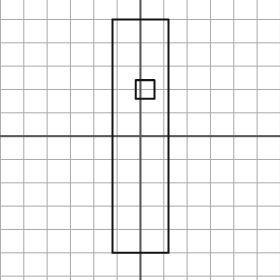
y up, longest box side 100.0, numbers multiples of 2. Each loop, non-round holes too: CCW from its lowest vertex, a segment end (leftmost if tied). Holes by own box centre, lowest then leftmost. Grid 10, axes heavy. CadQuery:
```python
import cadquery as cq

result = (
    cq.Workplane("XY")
    .moveTo(-12.0, -50.0)
    .lineTo(12.0, -50.0)
    .lineTo(12.0, 50.0)
    .lineTo(-12.0, 50.0)
    .close()
    .moveTo(-2.0, 16.0)
    .lineTo(6.0, 16.0)
    .lineTo(6.0, 24.0)
    .lineTo(-2.0, 24.0)
    .close()
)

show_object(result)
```